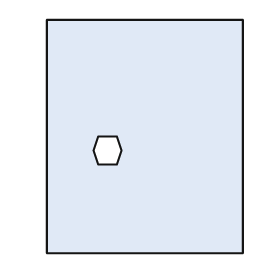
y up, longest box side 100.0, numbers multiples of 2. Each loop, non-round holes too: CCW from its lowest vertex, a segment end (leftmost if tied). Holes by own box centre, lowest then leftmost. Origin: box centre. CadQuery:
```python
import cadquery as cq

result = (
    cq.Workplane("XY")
    .moveTo(-42.0, -50.0)
    .lineTo(42.0, -50.0)
    .lineTo(42.0, 50.0)
    .lineTo(-42.0, 50.0)
    .close()
    .moveTo(-20.0, -12.0)
    .lineTo(-12.0, -12.0)
    .lineTo(-10.0, -6.0)
    .lineTo(-12.0, 0.0)
    .lineTo(-20.0, 0.0)
    .lineTo(-22.0, -6.0)
    .close()
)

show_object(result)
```